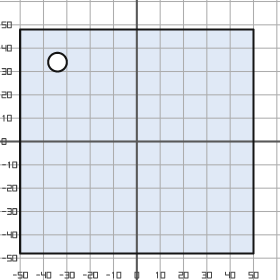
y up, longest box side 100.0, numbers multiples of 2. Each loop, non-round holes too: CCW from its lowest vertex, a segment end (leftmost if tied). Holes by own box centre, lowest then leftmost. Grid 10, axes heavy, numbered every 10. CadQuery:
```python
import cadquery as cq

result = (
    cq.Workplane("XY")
    .moveTo(-50.0, -48.0)
    .lineTo(50.0, -48.0)
    .lineTo(50.0, 48.0)
    .lineTo(-50.0, 48.0)
    .close()
    .moveTo(-34.0, 34.0)
    .circle(4.0)
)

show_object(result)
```